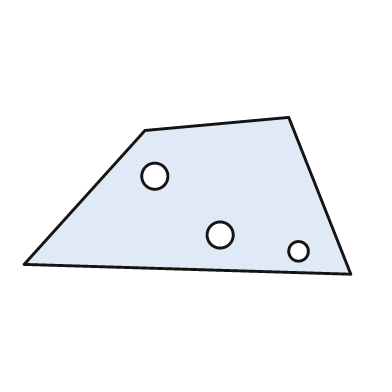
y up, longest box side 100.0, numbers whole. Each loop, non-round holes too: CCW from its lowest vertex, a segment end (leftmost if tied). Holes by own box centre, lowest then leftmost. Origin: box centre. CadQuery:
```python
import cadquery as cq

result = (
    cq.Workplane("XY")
    .moveTo(50.0, -24.0)
    .lineTo(31.0, 24.0)
    .lineTo(-13.0, 20.0)
    .lineTo(-50.0, -21.0)
    .close()
    .moveTo(34.0, -17.0)
    .circle(3.0)
    .moveTo(10.0, -12.0)
    .circle(4.0)
    .moveTo(-10.0, 6.0)
    .circle(4.0)
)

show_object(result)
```